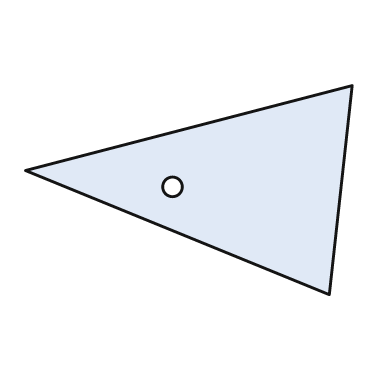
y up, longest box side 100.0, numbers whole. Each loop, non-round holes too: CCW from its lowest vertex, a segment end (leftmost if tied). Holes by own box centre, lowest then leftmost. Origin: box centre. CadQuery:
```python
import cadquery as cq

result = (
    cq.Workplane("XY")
    .moveTo(43.0, -32.0)
    .lineTo(50.0, 32.0)
    .lineTo(-50.0, 6.0)
    .close()
    .moveTo(-5.0, 1.0)
    .circle(3.0)
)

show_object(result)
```